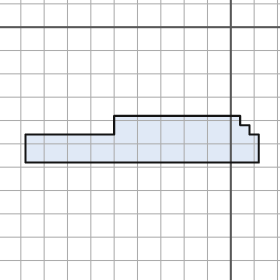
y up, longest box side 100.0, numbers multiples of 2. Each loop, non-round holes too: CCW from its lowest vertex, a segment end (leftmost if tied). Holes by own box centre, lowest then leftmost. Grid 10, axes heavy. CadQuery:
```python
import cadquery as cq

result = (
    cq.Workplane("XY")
    .moveTo(-88.0, -58.0)
    .lineTo(12.0, -58.0)
    .lineTo(12.0, -46.0)
    .lineTo(8.0, -46.0)
    .lineTo(8.0, -42.0)
    .lineTo(4.0, -42.0)
    .lineTo(4.0, -38.0)
    .lineTo(-50.0, -38.0)
    .lineTo(-50.0, -46.0)
    .lineTo(-88.0, -46.0)
    .close()
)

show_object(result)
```